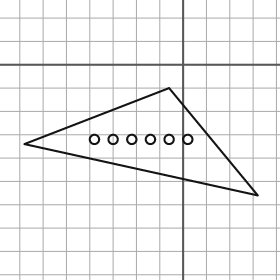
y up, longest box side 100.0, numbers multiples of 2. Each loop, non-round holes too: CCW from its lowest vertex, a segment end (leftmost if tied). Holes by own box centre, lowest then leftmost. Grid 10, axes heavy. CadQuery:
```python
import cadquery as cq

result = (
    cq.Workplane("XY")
    .moveTo(32.0, -56.0)
    .lineTo(-6.0, -10.0)
    .lineTo(-68.0, -34.0)
    .close()
    .moveTo(-38.0, -32.0)
    .circle(2.0)
    .moveTo(-30.0, -32.0)
    .circle(2.0)
    .moveTo(-22.0, -32.0)
    .circle(2.0)
    .moveTo(-14.0, -32.0)
    .circle(2.0)
    .moveTo(-6.0, -32.0)
    .circle(2.0)
    .moveTo(2.0, -32.0)
    .circle(2.0)
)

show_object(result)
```